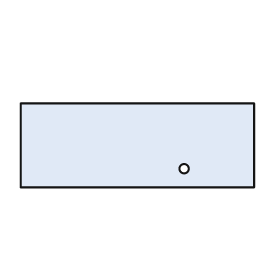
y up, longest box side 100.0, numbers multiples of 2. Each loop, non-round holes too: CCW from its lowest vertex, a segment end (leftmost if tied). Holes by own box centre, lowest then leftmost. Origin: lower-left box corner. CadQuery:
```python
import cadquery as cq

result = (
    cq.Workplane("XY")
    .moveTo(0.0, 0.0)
    .lineTo(100.0, 0.0)
    .lineTo(100.0, 36.0)
    .lineTo(0.0, 36.0)
    .close()
    .moveTo(70.0, 8.0)
    .circle(2.0)
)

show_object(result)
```